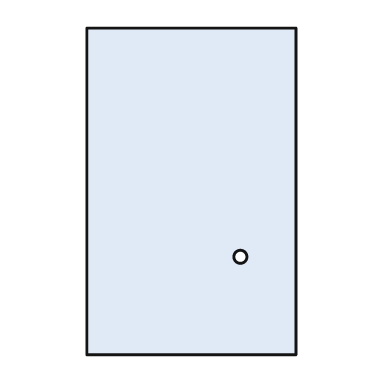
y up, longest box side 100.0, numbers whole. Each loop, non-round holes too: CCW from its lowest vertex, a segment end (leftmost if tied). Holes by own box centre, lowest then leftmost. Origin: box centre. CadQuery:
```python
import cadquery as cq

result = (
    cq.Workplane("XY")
    .moveTo(-32.0, -50.0)
    .lineTo(32.0, -50.0)
    .lineTo(32.0, 50.0)
    .lineTo(-32.0, 50.0)
    .close()
    .moveTo(15.0, -20.0)
    .circle(2.0)
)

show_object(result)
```